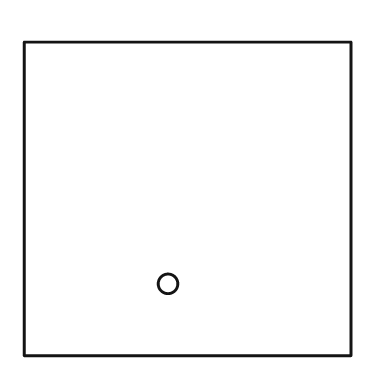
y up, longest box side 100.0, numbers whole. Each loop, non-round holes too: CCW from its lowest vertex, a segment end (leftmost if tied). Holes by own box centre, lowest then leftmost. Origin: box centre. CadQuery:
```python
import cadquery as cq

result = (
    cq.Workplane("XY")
    .moveTo(-50.0, -48.0)
    .lineTo(50.0, -48.0)
    .lineTo(50.0, 48.0)
    .lineTo(-50.0, 48.0)
    .close()
    .moveTo(-6.0, -26.0)
    .circle(3.0)
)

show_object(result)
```